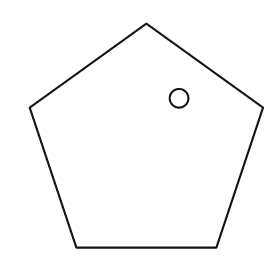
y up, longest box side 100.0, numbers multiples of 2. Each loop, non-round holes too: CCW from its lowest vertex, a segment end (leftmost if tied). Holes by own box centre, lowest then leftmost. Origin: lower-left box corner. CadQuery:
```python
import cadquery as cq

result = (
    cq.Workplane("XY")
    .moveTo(20.0, 0.0)
    .lineTo(80.0, 0.0)
    .lineTo(100.0, 60.0)
    .lineTo(50.0, 96.0)
    .lineTo(0.0, 60.0)
    .close()
    .moveTo(64.0, 64.0)
    .circle(4.0)
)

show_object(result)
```